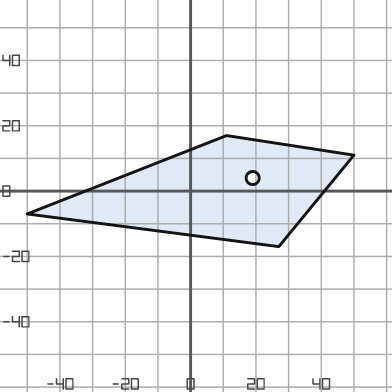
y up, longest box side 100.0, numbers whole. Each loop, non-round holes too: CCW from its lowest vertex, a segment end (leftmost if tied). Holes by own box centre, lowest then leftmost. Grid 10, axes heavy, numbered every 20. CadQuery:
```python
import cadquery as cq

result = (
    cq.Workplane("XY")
    .moveTo(27.0, -17.0)
    .lineTo(50.0, 11.0)
    .lineTo(11.0, 17.0)
    .lineTo(-50.0, -7.0)
    .close()
    .moveTo(19.0, 4.0)
    .circle(2.0)
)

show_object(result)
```